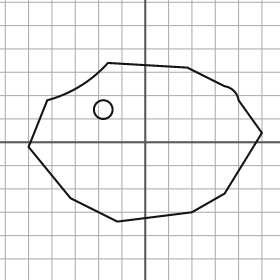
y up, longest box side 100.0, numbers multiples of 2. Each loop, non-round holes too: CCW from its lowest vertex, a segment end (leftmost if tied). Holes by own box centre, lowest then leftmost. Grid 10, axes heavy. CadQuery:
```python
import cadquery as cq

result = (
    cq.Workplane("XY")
    .moveTo(-12.0, -34.0)
    .lineTo(20.0, -30.0)
    .lineTo(34.0, -22.0)
    .lineTo(50.0, 4.0)
    .lineTo(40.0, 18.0)
    .threePointArc((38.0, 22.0), (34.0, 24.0))
    .lineTo(18.0, 32.0)
    .lineTo(-16.0, 34.0)
    .threePointArc((-28.0, 24.0), (-42.0, 18.0))
    .lineTo(-50.0, -2.0)
    .lineTo(-32.0, -24.0)
    .close()
    .moveTo(-18.0, 14.0)
    .circle(4.0)
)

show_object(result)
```